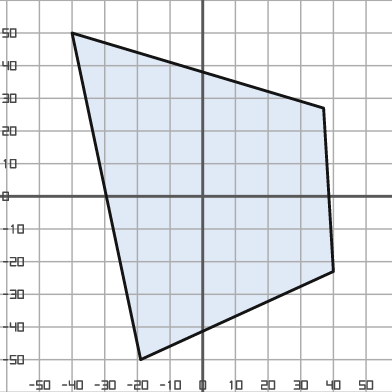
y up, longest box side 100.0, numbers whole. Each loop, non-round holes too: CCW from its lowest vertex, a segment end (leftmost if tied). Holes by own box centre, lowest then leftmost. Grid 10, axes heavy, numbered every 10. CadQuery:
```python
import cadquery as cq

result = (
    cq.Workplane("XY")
    .moveTo(-19.0, -50.0)
    .lineTo(40.0, -23.0)
    .lineTo(37.0, 27.0)
    .lineTo(-40.0, 50.0)
    .close()
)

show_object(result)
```